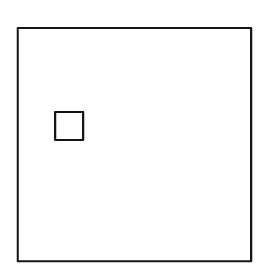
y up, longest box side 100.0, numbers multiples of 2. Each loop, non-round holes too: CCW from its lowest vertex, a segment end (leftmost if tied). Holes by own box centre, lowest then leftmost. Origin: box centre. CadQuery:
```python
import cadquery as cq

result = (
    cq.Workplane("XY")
    .moveTo(-50.0, -50.0)
    .lineTo(50.0, -50.0)
    .lineTo(50.0, 50.0)
    .lineTo(-50.0, 50.0)
    .close()
    .moveTo(-34.0, 2.0)
    .lineTo(-22.0, 2.0)
    .lineTo(-22.0, 14.0)
    .lineTo(-34.0, 14.0)
    .close()
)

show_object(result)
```